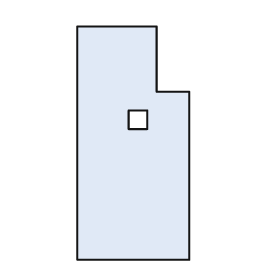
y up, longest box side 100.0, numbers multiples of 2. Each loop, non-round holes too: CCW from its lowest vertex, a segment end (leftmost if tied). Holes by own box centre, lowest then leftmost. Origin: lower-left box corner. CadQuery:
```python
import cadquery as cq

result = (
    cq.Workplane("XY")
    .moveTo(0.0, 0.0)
    .lineTo(48.0, 0.0)
    .lineTo(48.0, 72.0)
    .lineTo(34.0, 72.0)
    .lineTo(34.0, 100.0)
    .lineTo(0.0, 100.0)
    .close()
    .moveTo(22.0, 56.0)
    .lineTo(30.0, 56.0)
    .lineTo(30.0, 64.0)
    .lineTo(22.0, 64.0)
    .close()
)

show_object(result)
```